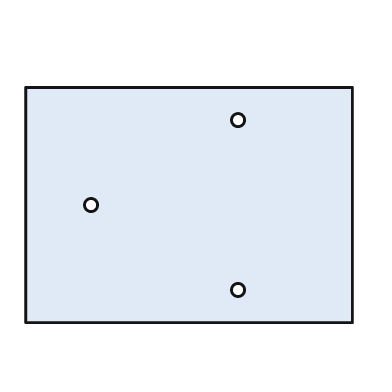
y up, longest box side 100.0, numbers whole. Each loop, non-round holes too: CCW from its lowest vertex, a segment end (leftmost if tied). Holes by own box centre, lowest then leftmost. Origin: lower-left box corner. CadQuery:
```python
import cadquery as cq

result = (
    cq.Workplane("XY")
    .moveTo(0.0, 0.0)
    .lineTo(100.0, 0.0)
    .lineTo(100.0, 72.0)
    .lineTo(0.0, 72.0)
    .close()
    .moveTo(65.0, 10.0)
    .circle(2.0)
    .moveTo(20.0, 36.0)
    .circle(2.0)
    .moveTo(65.0, 62.0)
    .circle(2.0)
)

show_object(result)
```